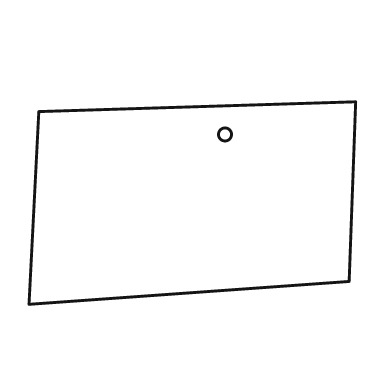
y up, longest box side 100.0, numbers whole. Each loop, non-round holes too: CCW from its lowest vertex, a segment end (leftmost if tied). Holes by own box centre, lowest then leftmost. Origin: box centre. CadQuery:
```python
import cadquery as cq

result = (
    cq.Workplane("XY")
    .moveTo(-50.0, -31.0)
    .lineTo(48.0, -24.0)
    .lineTo(50.0, 31.0)
    .lineTo(-47.0, 28.0)
    .close()
    .moveTo(10.0, 21.0)
    .circle(2.0)
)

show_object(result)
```